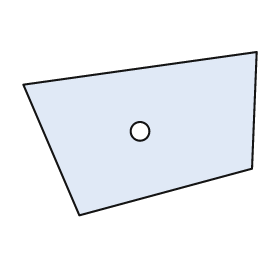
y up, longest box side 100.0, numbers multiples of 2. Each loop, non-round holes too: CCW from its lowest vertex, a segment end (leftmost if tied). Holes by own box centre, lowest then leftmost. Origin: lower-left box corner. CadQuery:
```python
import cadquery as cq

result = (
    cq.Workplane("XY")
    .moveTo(24.0, 0.0)
    .lineTo(98.0, 20.0)
    .lineTo(100.0, 70.0)
    .lineTo(0.0, 56.0)
    .close()
    .moveTo(50.0, 36.0)
    .circle(4.0)
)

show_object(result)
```